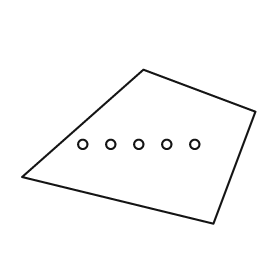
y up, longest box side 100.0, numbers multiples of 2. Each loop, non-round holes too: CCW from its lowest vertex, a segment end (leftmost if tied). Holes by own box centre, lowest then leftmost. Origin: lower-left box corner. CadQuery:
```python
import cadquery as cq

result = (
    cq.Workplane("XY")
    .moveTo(82.0, 0.0)
    .lineTo(100.0, 48.0)
    .lineTo(52.0, 66.0)
    .lineTo(0.0, 20.0)
    .close()
    .moveTo(26.0, 34.0)
    .circle(2.0)
    .moveTo(38.0, 34.0)
    .circle(2.0)
    .moveTo(50.0, 34.0)
    .circle(2.0)
    .moveTo(62.0, 34.0)
    .circle(2.0)
    .moveTo(74.0, 34.0)
    .circle(2.0)
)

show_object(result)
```